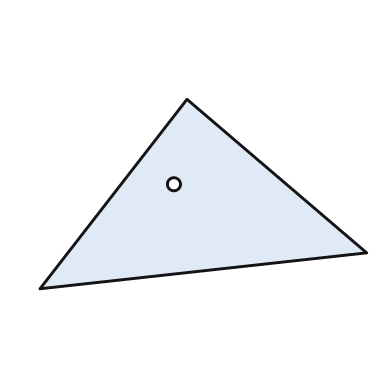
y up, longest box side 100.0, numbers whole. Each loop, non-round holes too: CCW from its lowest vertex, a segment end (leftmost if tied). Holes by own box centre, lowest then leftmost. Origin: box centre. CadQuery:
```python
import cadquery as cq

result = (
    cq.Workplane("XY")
    .moveTo(-50.0, -29.0)
    .lineTo(50.0, -18.0)
    .lineTo(-5.0, 29.0)
    .close()
    .moveTo(-9.0, 3.0)
    .circle(2.0)
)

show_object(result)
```